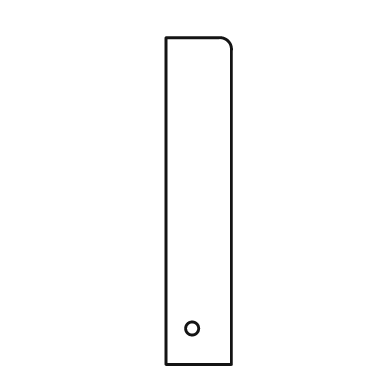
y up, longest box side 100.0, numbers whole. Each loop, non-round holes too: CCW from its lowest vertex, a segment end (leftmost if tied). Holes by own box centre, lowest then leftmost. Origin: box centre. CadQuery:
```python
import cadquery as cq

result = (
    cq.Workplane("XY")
    .moveTo(-10.0, -50.0)
    .lineTo(10.0, -50.0)
    .lineTo(10.0, 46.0)
    .threePointArc((9.0, 49.0), (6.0, 50.0))
    .lineTo(-10.0, 50.0)
    .close()
    .moveTo(-2.0, -39.0)
    .circle(2.0)
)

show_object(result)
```